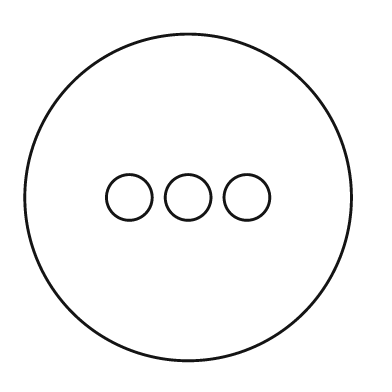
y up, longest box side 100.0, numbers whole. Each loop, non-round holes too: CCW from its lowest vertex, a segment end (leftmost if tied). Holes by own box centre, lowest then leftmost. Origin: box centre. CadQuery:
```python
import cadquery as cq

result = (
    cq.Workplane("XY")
    .moveTo(0.0, 0.0)
    .circle(50.0)
    .moveTo(-18.0, 0.0)
    .circle(7.0)
    .moveTo(0.0, 0.0)
    .circle(7.0)
    .moveTo(18.0, 0.0)
    .circle(7.0)
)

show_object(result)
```